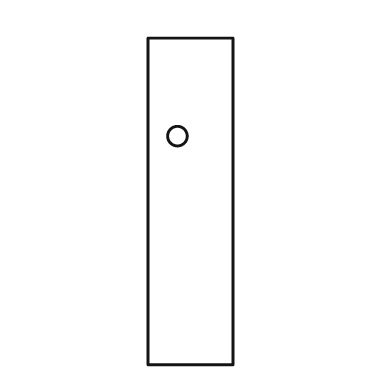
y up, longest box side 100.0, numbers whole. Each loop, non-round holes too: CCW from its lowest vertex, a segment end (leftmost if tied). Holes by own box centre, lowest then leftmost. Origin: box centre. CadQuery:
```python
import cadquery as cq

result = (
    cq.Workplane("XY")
    .moveTo(-13.0, -50.0)
    .lineTo(13.0, -50.0)
    .lineTo(13.0, 50.0)
    .lineTo(-13.0, 50.0)
    .close()
    .moveTo(-4.0, 20.0)
    .circle(3.0)
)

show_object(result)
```